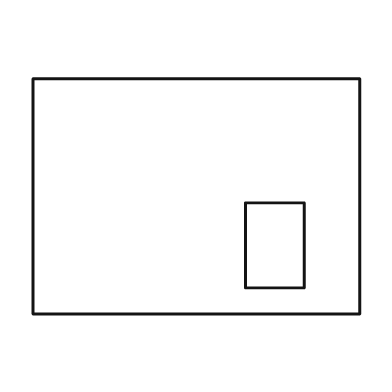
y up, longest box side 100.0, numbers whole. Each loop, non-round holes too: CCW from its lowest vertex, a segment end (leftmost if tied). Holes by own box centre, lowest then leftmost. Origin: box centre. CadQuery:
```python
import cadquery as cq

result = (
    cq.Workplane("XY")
    .moveTo(-50.0, -36.0)
    .lineTo(50.0, -36.0)
    .lineTo(50.0, 36.0)
    .lineTo(-50.0, 36.0)
    .close()
    .moveTo(15.0, -28.0)
    .lineTo(33.0, -28.0)
    .lineTo(33.0, -2.0)
    .lineTo(15.0, -2.0)
    .close()
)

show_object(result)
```